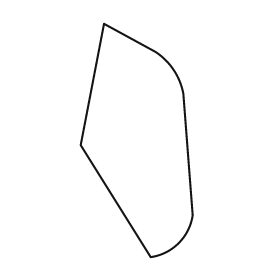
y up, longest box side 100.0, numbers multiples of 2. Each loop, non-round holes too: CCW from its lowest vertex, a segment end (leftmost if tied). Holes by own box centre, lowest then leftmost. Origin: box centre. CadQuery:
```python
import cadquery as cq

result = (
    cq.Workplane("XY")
    .moveTo(6.0, -50.0)
    .threePointArc((18.0, -44.0), (24.0, -32.0))
    .lineTo(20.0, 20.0)
    .threePointArc((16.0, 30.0), (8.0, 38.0))
    .lineTo(-14.0, 50.0)
    .lineTo(-24.0, -2.0)
    .close()
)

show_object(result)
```